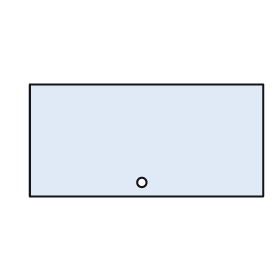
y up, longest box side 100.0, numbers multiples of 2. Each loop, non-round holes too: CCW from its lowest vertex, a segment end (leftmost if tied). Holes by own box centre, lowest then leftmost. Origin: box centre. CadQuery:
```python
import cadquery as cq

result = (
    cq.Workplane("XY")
    .moveTo(-50.0, -24.0)
    .lineTo(50.0, -24.0)
    .lineTo(50.0, 24.0)
    .lineTo(-50.0, 24.0)
    .close()
    .moveTo(-2.0, -18.0)
    .circle(2.0)
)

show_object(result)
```